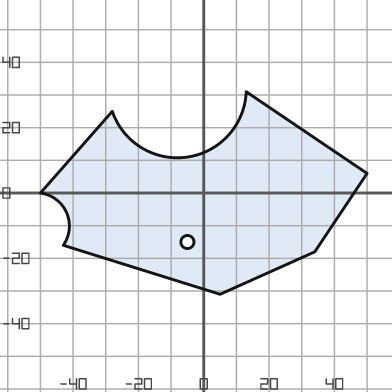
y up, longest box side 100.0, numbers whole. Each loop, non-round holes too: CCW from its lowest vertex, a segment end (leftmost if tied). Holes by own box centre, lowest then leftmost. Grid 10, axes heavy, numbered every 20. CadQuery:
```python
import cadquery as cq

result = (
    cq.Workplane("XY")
    .moveTo(5.0, -31.0)
    .lineTo(34.0, -18.0)
    .lineTo(50.0, 6.0)
    .lineTo(13.0, 31.0)
    .threePointArc((-5.0, 11.0), (-28.0, 25.0))
    .lineTo(-50.0, 0.0)
    .threePointArc((-42.0, -6.0), (-43.0, -16.0))
    .close()
    .moveTo(-5.0, -15.0)
    .circle(2.0)
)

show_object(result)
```